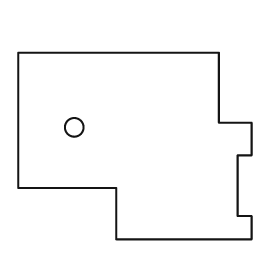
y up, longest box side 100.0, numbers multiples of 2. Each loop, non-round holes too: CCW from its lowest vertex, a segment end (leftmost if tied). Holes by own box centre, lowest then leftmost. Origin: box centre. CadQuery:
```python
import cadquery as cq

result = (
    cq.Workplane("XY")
    .moveTo(-8.0, -40.0)
    .lineTo(50.0, -40.0)
    .lineTo(50.0, -30.0)
    .lineTo(44.0, -30.0)
    .lineTo(44.0, -4.0)
    .lineTo(50.0, -4.0)
    .lineTo(50.0, 10.0)
    .lineTo(36.0, 10.0)
    .lineTo(36.0, 40.0)
    .lineTo(-50.0, 40.0)
    .lineTo(-50.0, -18.0)
    .lineTo(-8.0, -18.0)
    .close()
    .moveTo(-26.0, 8.0)
    .circle(4.0)
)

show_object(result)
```